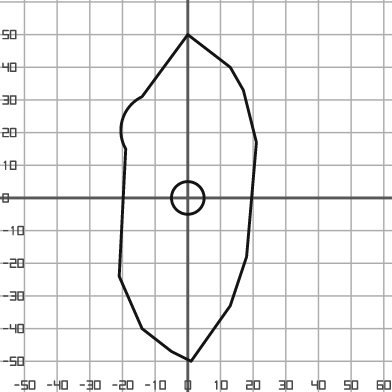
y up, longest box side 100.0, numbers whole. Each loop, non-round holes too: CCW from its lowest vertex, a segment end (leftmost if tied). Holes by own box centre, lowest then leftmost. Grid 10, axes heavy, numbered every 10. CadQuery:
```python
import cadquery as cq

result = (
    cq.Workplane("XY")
    .moveTo(1.0, -50.0)
    .lineTo(13.0, -33.0)
    .lineTo(18.0, -18.0)
    .lineTo(21.0, 17.0)
    .lineTo(17.0, 33.0)
    .lineTo(13.0, 40.0)
    .lineTo(0.0, 50.0)
    .lineTo(-14.0, 31.0)
    .threePointArc((-20.0, 24.0), (-19.0, 15.0))
    .lineTo(-21.0, -24.0)
    .lineTo(-14.0, -40.0)
    .lineTo(-5.0, -47.0)
    .close()
    .moveTo(0.0, 0.0)
    .circle(5.0)
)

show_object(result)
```